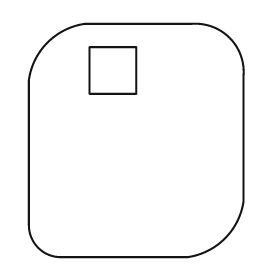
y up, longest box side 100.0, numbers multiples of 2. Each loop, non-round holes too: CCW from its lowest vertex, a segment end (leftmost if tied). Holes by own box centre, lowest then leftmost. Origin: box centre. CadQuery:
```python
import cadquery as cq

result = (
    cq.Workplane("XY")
    .moveTo(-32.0, -50.0)
    .lineTo(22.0, -50.0)
    .threePointArc((38.0, -42.0), (46.0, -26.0))
    .lineTo(46.0, 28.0)
    .threePointArc((40.0, 44.0), (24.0, 50.0))
    .lineTo(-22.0, 50.0)
    .threePointArc((-38.0, 42.0), (-46.0, 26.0))
    .lineTo(-46.0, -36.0)
    .threePointArc((-42.0, -46.0), (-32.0, -50.0))
    .close()
    .moveTo(-20.0, 20.0)
    .lineTo(0.0, 20.0)
    .lineTo(0.0, 40.0)
    .lineTo(-20.0, 40.0)
    .close()
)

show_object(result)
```